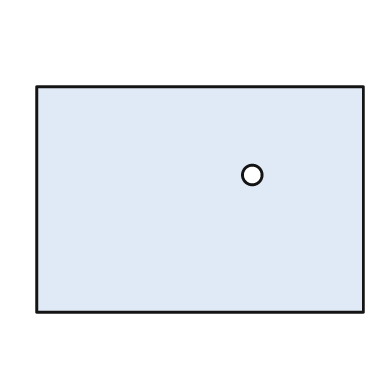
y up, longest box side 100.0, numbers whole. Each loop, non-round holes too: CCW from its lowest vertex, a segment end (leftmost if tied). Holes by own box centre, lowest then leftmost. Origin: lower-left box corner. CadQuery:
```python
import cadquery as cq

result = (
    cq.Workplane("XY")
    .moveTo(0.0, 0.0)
    .lineTo(100.0, 0.0)
    .lineTo(100.0, 69.0)
    .lineTo(0.0, 69.0)
    .close()
    .moveTo(66.0, 42.0)
    .circle(3.0)
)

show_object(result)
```